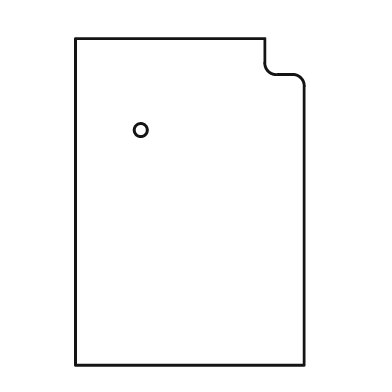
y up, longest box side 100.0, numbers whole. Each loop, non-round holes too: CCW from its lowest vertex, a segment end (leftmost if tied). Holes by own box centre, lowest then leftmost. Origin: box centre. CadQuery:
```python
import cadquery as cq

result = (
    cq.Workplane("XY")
    .moveTo(-35.0, -50.0)
    .lineTo(35.0, -50.0)
    .lineTo(35.0, 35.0)
    .threePointArc((34.0, 38.0), (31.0, 39.0))
    .lineTo(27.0, 39.0)
    .threePointArc((24.0, 40.0), (23.0, 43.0))
    .lineTo(23.0, 50.0)
    .lineTo(-35.0, 50.0)
    .close()
    .moveTo(-15.0, 22.0)
    .circle(2.0)
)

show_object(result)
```